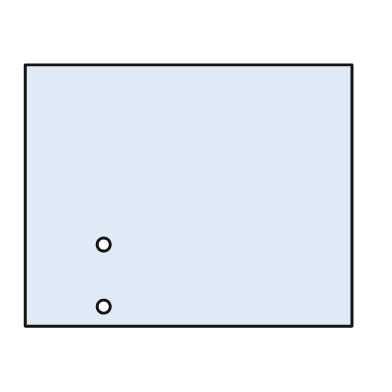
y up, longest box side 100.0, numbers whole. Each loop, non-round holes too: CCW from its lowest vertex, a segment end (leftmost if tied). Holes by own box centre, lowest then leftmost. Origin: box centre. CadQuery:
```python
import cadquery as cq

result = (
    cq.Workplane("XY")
    .moveTo(-50.0, -40.0)
    .lineTo(50.0, -40.0)
    .lineTo(50.0, 40.0)
    .lineTo(-50.0, 40.0)
    .close()
    .moveTo(-26.0, -34.0)
    .circle(2.0)
    .moveTo(-26.0, -15.0)
    .circle(2.0)
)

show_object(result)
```